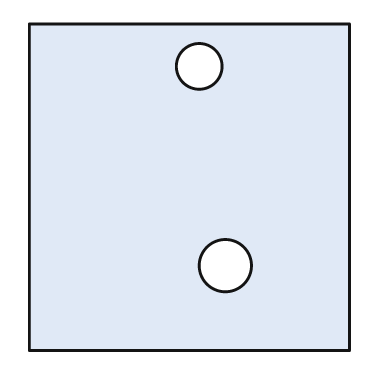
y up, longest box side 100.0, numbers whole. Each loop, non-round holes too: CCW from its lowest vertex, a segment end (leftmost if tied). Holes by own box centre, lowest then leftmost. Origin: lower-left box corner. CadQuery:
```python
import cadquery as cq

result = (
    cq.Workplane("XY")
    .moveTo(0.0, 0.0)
    .lineTo(98.0, 0.0)
    .lineTo(98.0, 100.0)
    .lineTo(0.0, 100.0)
    .close()
    .moveTo(60.0, 26.0)
    .circle(8.0)
    .moveTo(52.0, 87.0)
    .circle(7.0)
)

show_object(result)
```